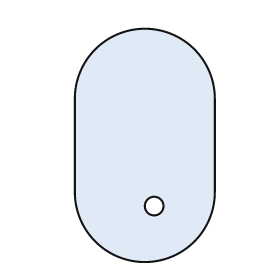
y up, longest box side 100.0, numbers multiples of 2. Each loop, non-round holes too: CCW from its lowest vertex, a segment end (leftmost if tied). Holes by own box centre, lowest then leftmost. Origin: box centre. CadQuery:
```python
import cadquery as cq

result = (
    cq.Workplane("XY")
    .moveTo(-30.0, -20.0)
    .threePointArc((0.0, -50.0), (30.0, -20.0))
    .lineTo(30.0, 20.0)
    .threePointArc((0.0, 50.0), (-30.0, 20.0))
    .close()
    .moveTo(4.0, -26.0)
    .circle(4.0)
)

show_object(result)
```